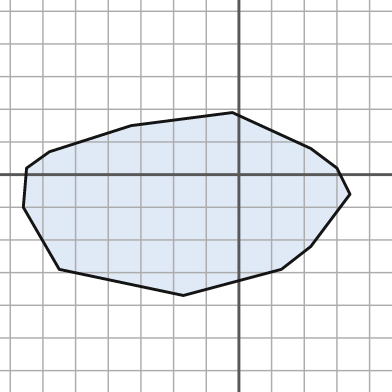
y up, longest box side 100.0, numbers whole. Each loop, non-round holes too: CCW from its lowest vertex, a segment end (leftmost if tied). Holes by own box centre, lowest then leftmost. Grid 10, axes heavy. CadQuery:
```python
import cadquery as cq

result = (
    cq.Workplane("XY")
    .moveTo(-17.0, -37.0)
    .lineTo(13.0, -29.0)
    .lineTo(22.0, -22.0)
    .lineTo(34.0, -6.0)
    .lineTo(30.0, 2.0)
    .lineTo(22.0, 8.0)
    .lineTo(-2.0, 19.0)
    .lineTo(-33.0, 15.0)
    .lineTo(-58.0, 7.0)
    .lineTo(-65.0, 2.0)
    .lineTo(-66.0, -10.0)
    .lineTo(-55.0, -29.0)
    .close()
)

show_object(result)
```